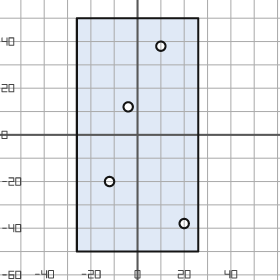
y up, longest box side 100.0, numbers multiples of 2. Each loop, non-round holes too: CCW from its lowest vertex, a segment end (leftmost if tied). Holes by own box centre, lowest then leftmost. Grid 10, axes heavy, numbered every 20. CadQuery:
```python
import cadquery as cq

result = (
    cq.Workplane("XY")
    .moveTo(-26.0, -50.0)
    .lineTo(26.0, -50.0)
    .lineTo(26.0, 50.0)
    .lineTo(-26.0, 50.0)
    .close()
    .moveTo(20.0, -38.0)
    .circle(2.0)
    .moveTo(-12.0, -20.0)
    .circle(2.0)
    .moveTo(-4.0, 12.0)
    .circle(2.0)
    .moveTo(10.0, 38.0)
    .circle(2.0)
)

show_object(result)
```